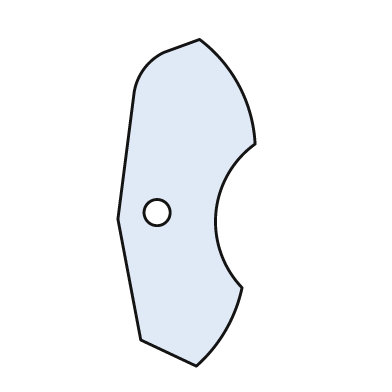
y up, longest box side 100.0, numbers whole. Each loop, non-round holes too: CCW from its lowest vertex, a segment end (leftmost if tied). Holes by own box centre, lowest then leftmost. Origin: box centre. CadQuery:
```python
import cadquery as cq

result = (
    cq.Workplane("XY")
    .moveTo(3.0, -50.0)
    .threePointArc((12.0, -39.0), (17.0, -26.0))
    .threePointArc((9.0, -3.0), (21.0, 18.0))
    .threePointArc((16.0, 36.0), (4.0, 50.0))
    .lineTo(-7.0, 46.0)
    .threePointArc((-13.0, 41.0), (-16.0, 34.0))
    .lineTo(-21.0, -5.0)
    .lineTo(-14.0, -42.0)
    .close()
    .moveTo(-9.0, -3.0)
    .circle(4.0)
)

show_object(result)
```